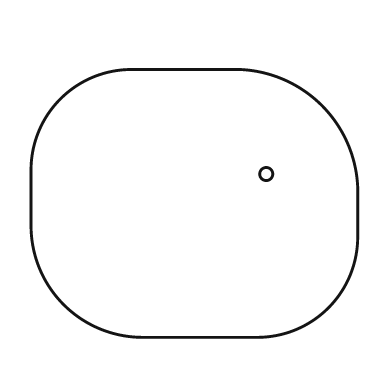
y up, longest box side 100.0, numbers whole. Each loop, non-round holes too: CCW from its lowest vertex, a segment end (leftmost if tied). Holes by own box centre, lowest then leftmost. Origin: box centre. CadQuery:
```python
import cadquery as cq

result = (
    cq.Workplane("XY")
    .moveTo(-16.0, -41.0)
    .lineTo(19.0, -41.0)
    .threePointArc((41.0, -32.0), (50.0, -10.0))
    .lineTo(50.0, 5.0)
    .threePointArc((39.0, 30.0), (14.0, 41.0))
    .lineTo(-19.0, 41.0)
    .threePointArc((-41.0, 32.0), (-50.0, 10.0))
    .lineTo(-50.0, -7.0)
    .threePointArc((-40.0, -31.0), (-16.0, -41.0))
    .close()
    .moveTo(22.0, 9.0)
    .circle(2.0)
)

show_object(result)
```